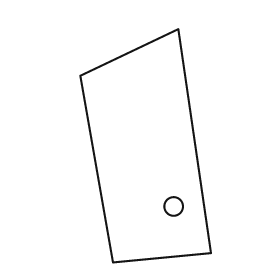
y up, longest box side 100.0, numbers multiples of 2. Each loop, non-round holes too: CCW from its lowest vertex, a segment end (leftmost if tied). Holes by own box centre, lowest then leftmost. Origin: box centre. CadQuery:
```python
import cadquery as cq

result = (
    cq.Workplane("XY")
    .moveTo(-14.0, -50.0)
    .lineTo(28.0, -46.0)
    .lineTo(14.0, 50.0)
    .lineTo(-28.0, 30.0)
    .close()
    .moveTo(12.0, -26.0)
    .circle(4.0)
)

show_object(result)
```